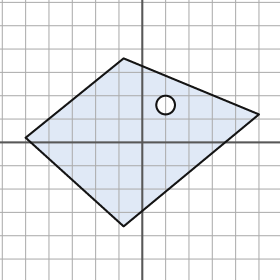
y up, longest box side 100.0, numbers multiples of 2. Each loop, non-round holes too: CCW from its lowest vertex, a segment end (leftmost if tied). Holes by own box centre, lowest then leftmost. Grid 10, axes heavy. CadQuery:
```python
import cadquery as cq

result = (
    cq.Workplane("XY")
    .moveTo(-8.0, -36.0)
    .lineTo(50.0, 12.0)
    .lineTo(-8.0, 36.0)
    .lineTo(-50.0, 2.0)
    .close()
    .moveTo(10.0, 16.0)
    .circle(4.0)
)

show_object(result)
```